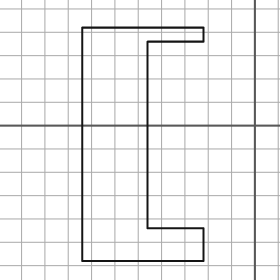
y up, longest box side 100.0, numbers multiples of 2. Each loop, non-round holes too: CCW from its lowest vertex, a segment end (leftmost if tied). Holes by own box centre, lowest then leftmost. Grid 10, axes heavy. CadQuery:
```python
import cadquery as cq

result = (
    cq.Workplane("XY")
    .moveTo(-74.0, -58.0)
    .lineTo(-22.0, -58.0)
    .lineTo(-22.0, -44.0)
    .lineTo(-46.0, -44.0)
    .lineTo(-46.0, 36.0)
    .lineTo(-22.0, 36.0)
    .lineTo(-22.0, 42.0)
    .lineTo(-74.0, 42.0)
    .close()
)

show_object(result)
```